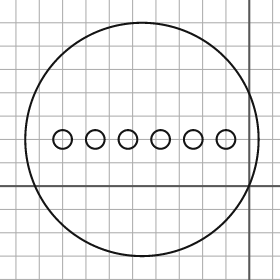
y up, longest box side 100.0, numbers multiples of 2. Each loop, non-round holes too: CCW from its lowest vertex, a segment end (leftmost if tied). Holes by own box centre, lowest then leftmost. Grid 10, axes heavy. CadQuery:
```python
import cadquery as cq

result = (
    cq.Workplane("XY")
    .moveTo(-46.0, 20.0)
    .circle(50.0)
    .moveTo(-80.0, 20.0)
    .circle(4.0)
    .moveTo(-66.0, 20.0)
    .circle(4.0)
    .moveTo(-52.0, 20.0)
    .circle(4.0)
    .moveTo(-38.0, 20.0)
    .circle(4.0)
    .moveTo(-24.0, 20.0)
    .circle(4.0)
    .moveTo(-10.0, 20.0)
    .circle(4.0)
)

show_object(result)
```